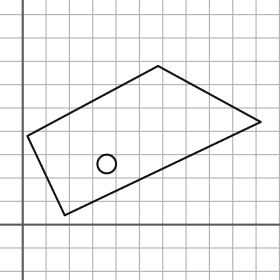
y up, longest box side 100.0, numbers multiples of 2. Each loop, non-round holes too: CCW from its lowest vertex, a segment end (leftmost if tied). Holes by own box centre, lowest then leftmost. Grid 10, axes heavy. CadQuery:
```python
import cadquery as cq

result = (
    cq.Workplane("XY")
    .moveTo(18.0, 4.0)
    .lineTo(102.0, 44.0)
    .lineTo(58.0, 68.0)
    .lineTo(2.0, 38.0)
    .close()
    .moveTo(36.0, 26.0)
    .circle(4.0)
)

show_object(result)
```